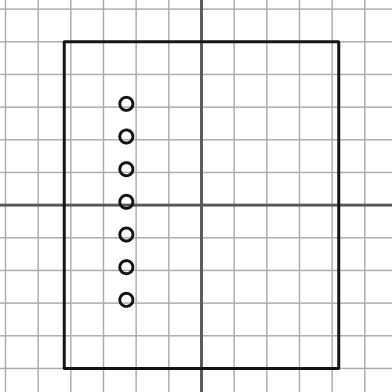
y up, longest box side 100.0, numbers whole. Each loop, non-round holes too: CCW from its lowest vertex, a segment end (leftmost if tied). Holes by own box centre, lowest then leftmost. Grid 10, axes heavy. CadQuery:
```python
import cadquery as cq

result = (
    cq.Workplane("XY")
    .moveTo(-42.0, -50.0)
    .lineTo(42.0, -50.0)
    .lineTo(42.0, 50.0)
    .lineTo(-42.0, 50.0)
    .close()
    .moveTo(-23.0, -29.0)
    .circle(2.0)
    .moveTo(-23.0, -19.0)
    .circle(2.0)
    .moveTo(-23.0, -9.0)
    .circle(2.0)
    .moveTo(-23.0, 1.0)
    .circle(2.0)
    .moveTo(-23.0, 11.0)
    .circle(2.0)
    .moveTo(-23.0, 21.0)
    .circle(2.0)
    .moveTo(-23.0, 31.0)
    .circle(2.0)
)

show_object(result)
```